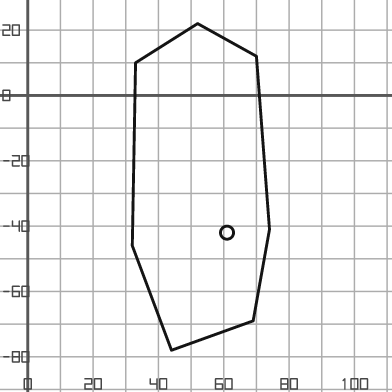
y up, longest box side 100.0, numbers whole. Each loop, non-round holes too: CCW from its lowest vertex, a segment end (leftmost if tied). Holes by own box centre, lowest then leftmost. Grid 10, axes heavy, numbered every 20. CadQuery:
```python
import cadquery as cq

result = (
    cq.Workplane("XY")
    .moveTo(44.0, -78.0)
    .lineTo(69.0, -69.0)
    .lineTo(74.0, -41.0)
    .lineTo(70.0, 12.0)
    .lineTo(52.0, 22.0)
    .lineTo(33.0, 10.0)
    .lineTo(32.0, -46.0)
    .close()
    .moveTo(61.0, -42.0)
    .circle(2.0)
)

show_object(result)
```